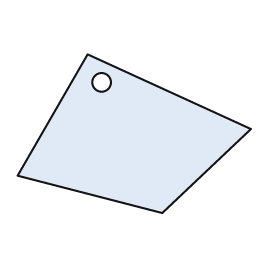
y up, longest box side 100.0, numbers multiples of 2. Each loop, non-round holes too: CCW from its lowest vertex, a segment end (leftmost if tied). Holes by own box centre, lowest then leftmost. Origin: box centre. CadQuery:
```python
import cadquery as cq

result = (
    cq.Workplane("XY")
    .moveTo(12.0, -34.0)
    .lineTo(50.0, 2.0)
    .lineTo(-20.0, 34.0)
    .lineTo(-50.0, -18.0)
    .close()
    .moveTo(-14.0, 22.0)
    .circle(4.0)
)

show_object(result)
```